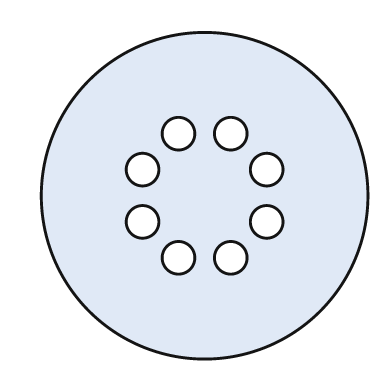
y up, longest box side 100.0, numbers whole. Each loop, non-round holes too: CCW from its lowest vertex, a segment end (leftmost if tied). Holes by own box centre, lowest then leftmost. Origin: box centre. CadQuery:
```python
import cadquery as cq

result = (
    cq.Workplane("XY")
    .moveTo(0.0, 0.0)
    .circle(50.0)
    .moveTo(-8.0, -19.0)
    .circle(5.0)
    .moveTo(8.0, -19.0)
    .circle(5.0)
    .moveTo(-19.0, -8.0)
    .circle(5.0)
    .moveTo(19.0, -8.0)
    .circle(5.0)
    .moveTo(-19.0, 8.0)
    .circle(5.0)
    .moveTo(19.0, 8.0)
    .circle(5.0)
    .moveTo(-8.0, 19.0)
    .circle(5.0)
    .moveTo(8.0, 19.0)
    .circle(5.0)
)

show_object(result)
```